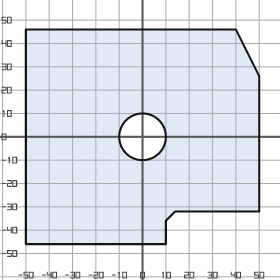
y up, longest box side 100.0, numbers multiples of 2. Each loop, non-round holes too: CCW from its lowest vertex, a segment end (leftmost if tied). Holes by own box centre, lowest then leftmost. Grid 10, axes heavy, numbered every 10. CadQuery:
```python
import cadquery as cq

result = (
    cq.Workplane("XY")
    .moveTo(-50.0, -46.0)
    .lineTo(10.0, -46.0)
    .lineTo(10.0, -36.0)
    .lineTo(14.0, -32.0)
    .lineTo(50.0, -32.0)
    .lineTo(50.0, 26.0)
    .lineTo(40.0, 46.0)
    .lineTo(-50.0, 46.0)
    .close()
    .moveTo(0.0, 0.0)
    .circle(10.0)
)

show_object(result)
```